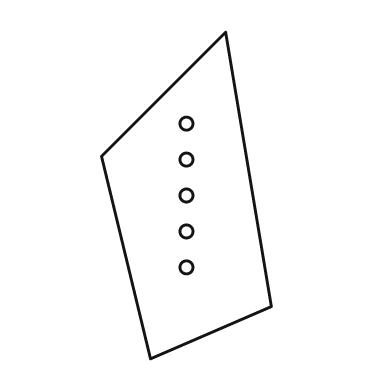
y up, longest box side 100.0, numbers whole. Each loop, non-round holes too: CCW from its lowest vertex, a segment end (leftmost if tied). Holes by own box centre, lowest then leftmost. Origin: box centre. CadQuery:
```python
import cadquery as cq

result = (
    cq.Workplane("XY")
    .moveTo(-11.0, -50.0)
    .lineTo(26.0, -34.0)
    .lineTo(12.0, 50.0)
    .lineTo(-26.0, 12.0)
    .close()
    .moveTo(0.0, -22.0)
    .circle(2.0)
    .moveTo(0.0, -11.0)
    .circle(2.0)
    .moveTo(0.0, 0.0)
    .circle(2.0)
    .moveTo(0.0, 11.0)
    .circle(2.0)
    .moveTo(0.0, 22.0)
    .circle(2.0)
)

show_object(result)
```